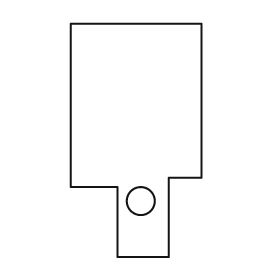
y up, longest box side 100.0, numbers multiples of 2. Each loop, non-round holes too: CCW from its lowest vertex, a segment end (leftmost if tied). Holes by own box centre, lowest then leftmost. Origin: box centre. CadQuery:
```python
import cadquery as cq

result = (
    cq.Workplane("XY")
    .moveTo(-8.0, -50.0)
    .lineTo(14.0, -50.0)
    .lineTo(14.0, -16.0)
    .lineTo(28.0, -16.0)
    .lineTo(28.0, 50.0)
    .lineTo(-28.0, 50.0)
    .lineTo(-28.0, -20.0)
    .lineTo(-8.0, -20.0)
    .close()
    .moveTo(2.0, -26.0)
    .circle(6.0)
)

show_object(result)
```